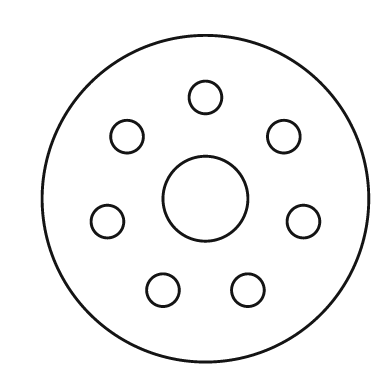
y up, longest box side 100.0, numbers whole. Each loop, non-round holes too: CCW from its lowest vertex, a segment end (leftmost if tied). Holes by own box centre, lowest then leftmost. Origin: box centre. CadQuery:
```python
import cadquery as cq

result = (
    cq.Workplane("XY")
    .moveTo(0.0, 0.0)
    .circle(50.0)
    .moveTo(-13.0, -28.0)
    .circle(5.0)
    .moveTo(13.0, -28.0)
    .circle(5.0)
    .moveTo(-30.0, -7.0)
    .circle(5.0)
    .moveTo(30.0, -7.0)
    .circle(5.0)
    .moveTo(0.0, 0.0)
    .circle(13.0)
    .moveTo(-24.0, 19.0)
    .circle(5.0)
    .moveTo(24.0, 19.0)
    .circle(5.0)
    .moveTo(0.0, 31.0)
    .circle(5.0)
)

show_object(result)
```